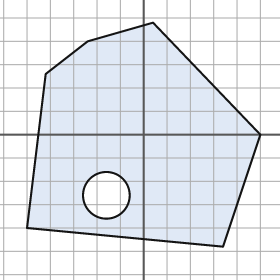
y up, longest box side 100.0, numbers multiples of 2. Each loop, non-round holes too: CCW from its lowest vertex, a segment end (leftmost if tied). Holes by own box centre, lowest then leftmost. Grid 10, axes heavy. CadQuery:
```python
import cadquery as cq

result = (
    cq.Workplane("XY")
    .moveTo(34.0, -48.0)
    .lineTo(50.0, 0.0)
    .lineTo(4.0, 48.0)
    .lineTo(-24.0, 40.0)
    .lineTo(-42.0, 26.0)
    .lineTo(-50.0, -40.0)
    .close()
    .moveTo(-16.0, -26.0)
    .circle(10.0)
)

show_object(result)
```